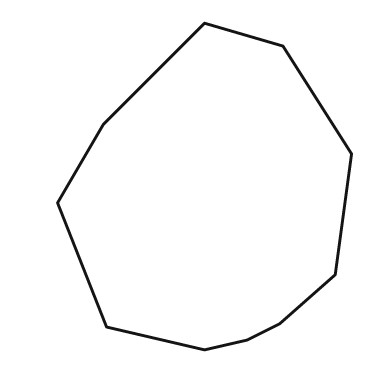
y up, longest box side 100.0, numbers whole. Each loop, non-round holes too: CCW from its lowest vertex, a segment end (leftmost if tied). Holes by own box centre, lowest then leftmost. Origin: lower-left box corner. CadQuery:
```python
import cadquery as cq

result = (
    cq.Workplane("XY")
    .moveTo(45.0, 0.0)
    .lineTo(58.0, 3.0)
    .lineTo(68.0, 8.0)
    .lineTo(85.0, 23.0)
    .lineTo(90.0, 60.0)
    .lineTo(69.0, 93.0)
    .lineTo(45.0, 100.0)
    .lineTo(14.0, 69.0)
    .lineTo(0.0, 45.0)
    .lineTo(15.0, 7.0)
    .close()
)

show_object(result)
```